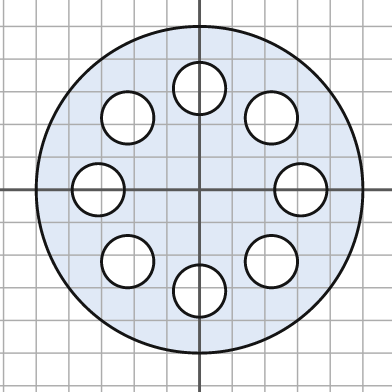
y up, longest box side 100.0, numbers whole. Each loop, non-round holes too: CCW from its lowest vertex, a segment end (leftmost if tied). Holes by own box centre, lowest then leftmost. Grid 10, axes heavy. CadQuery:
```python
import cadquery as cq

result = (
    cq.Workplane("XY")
    .moveTo(0.0, 0.0)
    .circle(50.0)
    .moveTo(0.0, -31.0)
    .circle(8.0)
    .moveTo(-22.0, -22.0)
    .circle(8.0)
    .moveTo(22.0, -22.0)
    .circle(8.0)
    .moveTo(-31.0, 0.0)
    .circle(8.0)
    .moveTo(31.0, 0.0)
    .circle(8.0)
    .moveTo(-22.0, 22.0)
    .circle(8.0)
    .moveTo(22.0, 22.0)
    .circle(8.0)
    .moveTo(0.0, 31.0)
    .circle(8.0)
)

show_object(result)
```